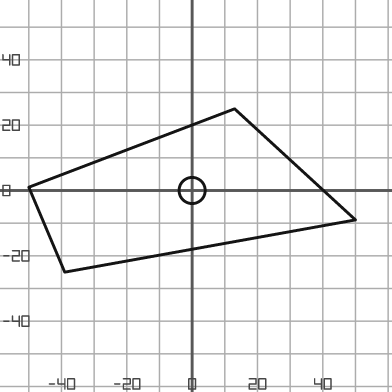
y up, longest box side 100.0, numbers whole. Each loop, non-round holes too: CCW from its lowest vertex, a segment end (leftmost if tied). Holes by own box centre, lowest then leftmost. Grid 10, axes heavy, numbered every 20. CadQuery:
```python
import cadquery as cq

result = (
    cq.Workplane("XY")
    .moveTo(-39.0, -25.0)
    .lineTo(50.0, -9.0)
    .lineTo(13.0, 25.0)
    .lineTo(-50.0, 1.0)
    .close()
    .moveTo(0.0, 0.0)
    .circle(4.0)
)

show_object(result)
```